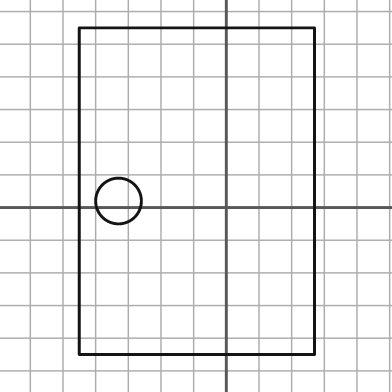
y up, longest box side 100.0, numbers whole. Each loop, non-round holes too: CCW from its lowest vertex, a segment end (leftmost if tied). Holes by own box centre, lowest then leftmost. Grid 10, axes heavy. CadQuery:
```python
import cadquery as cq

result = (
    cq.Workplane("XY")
    .moveTo(-45.0, -45.0)
    .lineTo(27.0, -45.0)
    .lineTo(27.0, 55.0)
    .lineTo(-45.0, 55.0)
    .close()
    .moveTo(-33.0, 2.0)
    .circle(7.0)
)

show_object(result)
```